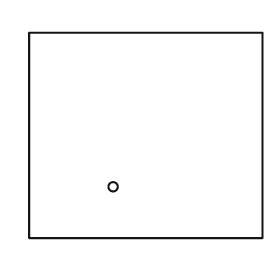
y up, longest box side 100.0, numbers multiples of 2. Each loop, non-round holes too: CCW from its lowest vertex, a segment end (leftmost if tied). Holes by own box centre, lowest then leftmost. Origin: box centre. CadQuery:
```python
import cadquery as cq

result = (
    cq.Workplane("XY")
    .moveTo(-50.0, -44.0)
    .lineTo(50.0, -44.0)
    .lineTo(50.0, 44.0)
    .lineTo(-50.0, 44.0)
    .close()
    .moveTo(-14.0, -22.0)
    .circle(2.0)
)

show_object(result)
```